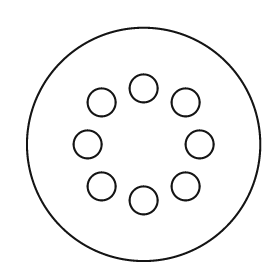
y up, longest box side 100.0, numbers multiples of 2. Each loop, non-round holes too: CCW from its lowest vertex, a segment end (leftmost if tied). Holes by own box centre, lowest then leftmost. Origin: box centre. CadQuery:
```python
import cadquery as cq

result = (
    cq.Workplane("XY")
    .moveTo(0.0, 0.0)
    .circle(50.0)
    .moveTo(0.0, -24.0)
    .circle(6.0)
    .moveTo(-18.0, -18.0)
    .circle(6.0)
    .moveTo(18.0, -18.0)
    .circle(6.0)
    .moveTo(-24.0, 0.0)
    .circle(6.0)
    .moveTo(24.0, 0.0)
    .circle(6.0)
    .moveTo(-18.0, 18.0)
    .circle(6.0)
    .moveTo(18.0, 18.0)
    .circle(6.0)
    .moveTo(0.0, 24.0)
    .circle(6.0)
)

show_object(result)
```